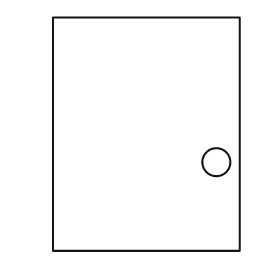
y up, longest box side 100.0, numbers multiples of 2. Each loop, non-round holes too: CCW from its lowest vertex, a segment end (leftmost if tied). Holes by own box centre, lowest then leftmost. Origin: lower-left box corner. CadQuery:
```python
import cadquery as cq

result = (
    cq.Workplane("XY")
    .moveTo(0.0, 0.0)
    .lineTo(80.0, 0.0)
    .lineTo(80.0, 100.0)
    .lineTo(0.0, 100.0)
    .close()
    .moveTo(70.0, 38.0)
    .circle(6.0)
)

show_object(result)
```